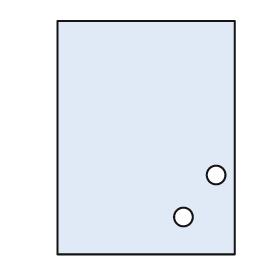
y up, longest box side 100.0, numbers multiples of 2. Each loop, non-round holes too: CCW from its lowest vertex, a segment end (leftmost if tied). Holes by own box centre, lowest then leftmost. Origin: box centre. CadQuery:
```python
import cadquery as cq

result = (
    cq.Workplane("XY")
    .moveTo(-38.0, -50.0)
    .lineTo(38.0, -50.0)
    .lineTo(38.0, 50.0)
    .lineTo(-38.0, 50.0)
    .close()
    .moveTo(16.0, -34.0)
    .circle(4.0)
    .moveTo(30.0, -16.0)
    .circle(4.0)
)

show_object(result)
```